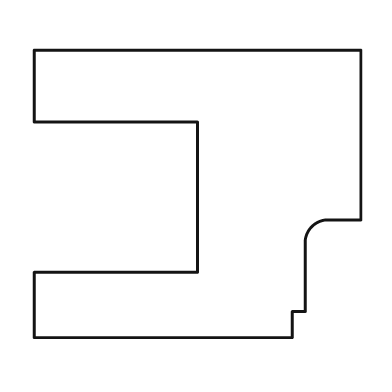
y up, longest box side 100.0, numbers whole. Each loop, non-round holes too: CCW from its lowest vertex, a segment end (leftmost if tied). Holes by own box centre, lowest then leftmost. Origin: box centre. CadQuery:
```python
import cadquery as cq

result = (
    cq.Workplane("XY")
    .moveTo(-50.0, -44.0)
    .lineTo(29.0, -44.0)
    .lineTo(29.0, -36.0)
    .lineTo(33.0, -36.0)
    .lineTo(33.0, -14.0)
    .threePointArc((35.0, -10.0), (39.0, -8.0))
    .lineTo(50.0, -8.0)
    .lineTo(50.0, 44.0)
    .lineTo(-50.0, 44.0)
    .lineTo(-50.0, 22.0)
    .lineTo(0.0, 22.0)
    .lineTo(0.0, -24.0)
    .lineTo(-50.0, -24.0)
    .close()
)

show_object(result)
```